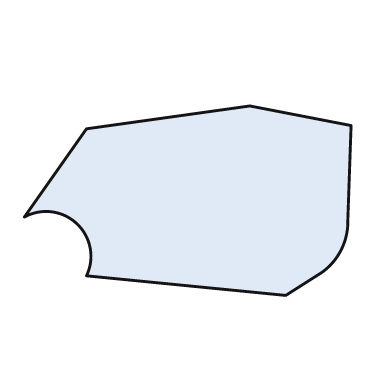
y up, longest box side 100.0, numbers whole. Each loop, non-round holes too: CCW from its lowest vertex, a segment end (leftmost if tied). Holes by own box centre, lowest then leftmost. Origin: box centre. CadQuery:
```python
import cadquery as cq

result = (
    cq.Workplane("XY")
    .moveTo(30.0, -29.0)
    .lineTo(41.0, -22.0)
    .threePointArc((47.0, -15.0), (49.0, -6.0))
    .lineTo(50.0, 23.0)
    .lineTo(19.0, 29.0)
    .lineTo(-31.0, 22.0)
    .lineTo(-50.0, -5.0)
    .threePointArc((-34.0, -7.0), (-31.0, -23.0))
    .close()
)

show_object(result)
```